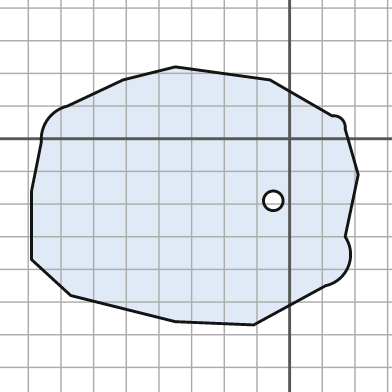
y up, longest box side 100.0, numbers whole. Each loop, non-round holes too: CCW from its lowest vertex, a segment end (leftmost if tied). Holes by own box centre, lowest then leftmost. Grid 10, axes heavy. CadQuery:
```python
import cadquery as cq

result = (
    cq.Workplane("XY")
    .moveTo(-11.0, -57.0)
    .lineTo(11.0, -45.0)
    .threePointArc((18.0, -39.0), (17.0, -30.0))
    .lineTo(21.0, -11.0)
    .lineTo(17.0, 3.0)
    .threePointArc((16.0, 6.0), (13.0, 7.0))
    .lineTo(-6.0, 18.0)
    .lineTo(-35.0, 22.0)
    .lineTo(-51.0, 18.0)
    .lineTo(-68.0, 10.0)
    .threePointArc((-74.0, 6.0), (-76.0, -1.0))
    .lineTo(-79.0, -16.0)
    .lineTo(-79.0, -37.0)
    .lineTo(-67.0, -48.0)
    .lineTo(-35.0, -56.0)
    .close()
    .moveTo(-5.0, -19.0)
    .circle(3.0)
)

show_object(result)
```